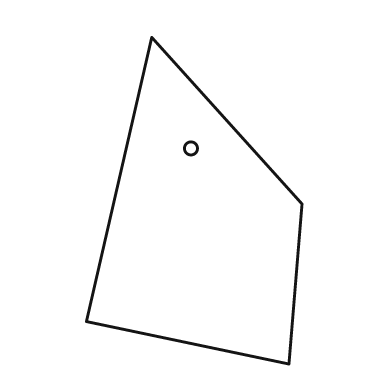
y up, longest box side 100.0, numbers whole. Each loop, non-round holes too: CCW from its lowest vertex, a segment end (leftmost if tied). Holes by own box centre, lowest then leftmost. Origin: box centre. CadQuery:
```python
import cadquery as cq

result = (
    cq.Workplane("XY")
    .moveTo(29.0, -50.0)
    .lineTo(33.0, -1.0)
    .lineTo(-13.0, 50.0)
    .lineTo(-33.0, -37.0)
    .close()
    .moveTo(-1.0, 16.0)
    .circle(2.0)
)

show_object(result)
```